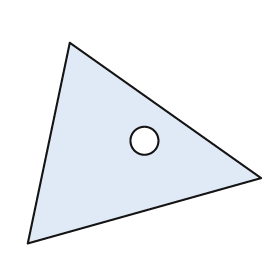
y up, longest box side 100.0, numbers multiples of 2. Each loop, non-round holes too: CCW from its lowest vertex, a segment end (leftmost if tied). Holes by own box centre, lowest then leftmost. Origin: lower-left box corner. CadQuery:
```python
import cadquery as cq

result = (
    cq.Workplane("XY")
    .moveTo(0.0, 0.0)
    .lineTo(100.0, 28.0)
    .lineTo(18.0, 86.0)
    .close()
    .moveTo(50.0, 44.0)
    .circle(6.0)
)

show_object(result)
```